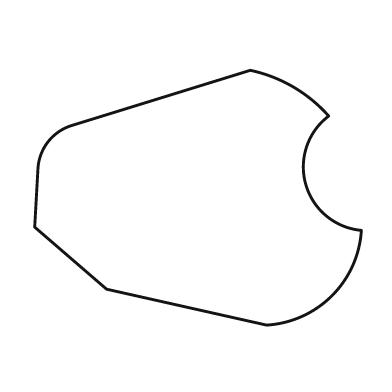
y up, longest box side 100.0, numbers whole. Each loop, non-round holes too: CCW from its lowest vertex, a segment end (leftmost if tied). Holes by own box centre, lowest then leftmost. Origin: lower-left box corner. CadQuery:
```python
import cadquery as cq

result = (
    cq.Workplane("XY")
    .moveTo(71.0, 0.0)
    .threePointArc((91.0, 9.0), (100.0, 29.0))
    .threePointArc((83.0, 43.0), (90.0, 64.0))
    .threePointArc((79.0, 73.0), (66.0, 78.0))
    .lineTo(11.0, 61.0)
    .threePointArc((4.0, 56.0), (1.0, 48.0))
    .lineTo(0.0, 30.0)
    .lineTo(22.0, 11.0)
    .close()
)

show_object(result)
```